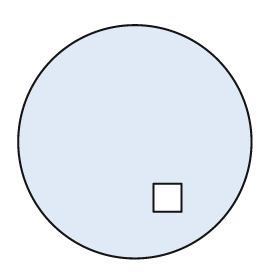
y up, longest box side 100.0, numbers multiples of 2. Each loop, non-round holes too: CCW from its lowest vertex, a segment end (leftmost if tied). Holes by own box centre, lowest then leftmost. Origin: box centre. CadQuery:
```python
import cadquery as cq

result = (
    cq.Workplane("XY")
    .moveTo(0.0, 0.0)
    .circle(50.0)
    .moveTo(8.0, -30.0)
    .lineTo(20.0, -30.0)
    .lineTo(20.0, -18.0)
    .lineTo(8.0, -18.0)
    .close()
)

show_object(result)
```